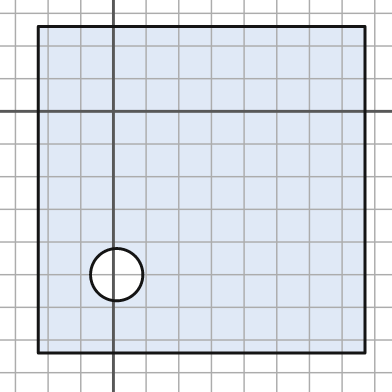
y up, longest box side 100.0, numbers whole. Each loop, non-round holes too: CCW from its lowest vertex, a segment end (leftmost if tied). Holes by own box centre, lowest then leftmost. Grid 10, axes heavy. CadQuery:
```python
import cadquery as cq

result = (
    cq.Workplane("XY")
    .moveTo(-23.0, -74.0)
    .lineTo(77.0, -74.0)
    .lineTo(77.0, 26.0)
    .lineTo(-23.0, 26.0)
    .close()
    .moveTo(1.0, -50.0)
    .circle(8.0)
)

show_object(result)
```